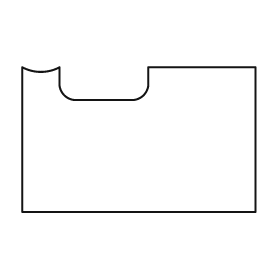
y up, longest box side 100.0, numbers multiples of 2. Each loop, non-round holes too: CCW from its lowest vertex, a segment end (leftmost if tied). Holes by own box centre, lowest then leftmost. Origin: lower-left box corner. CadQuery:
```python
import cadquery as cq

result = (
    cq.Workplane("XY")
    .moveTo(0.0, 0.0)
    .lineTo(100.0, 0.0)
    .lineTo(100.0, 62.0)
    .lineTo(54.0, 62.0)
    .lineTo(54.0, 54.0)
    .threePointArc((52.0, 50.0), (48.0, 48.0))
    .lineTo(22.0, 48.0)
    .threePointArc((18.0, 50.0), (16.0, 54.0))
    .lineTo(16.0, 62.0)
    .threePointArc((8.0, 60.0), (0.0, 62.0))
    .close()
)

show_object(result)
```